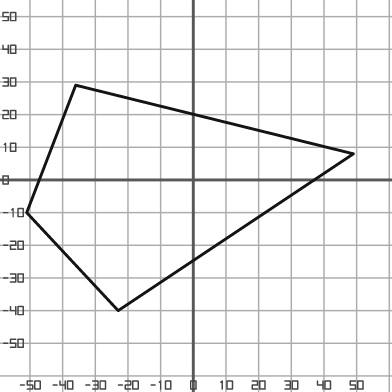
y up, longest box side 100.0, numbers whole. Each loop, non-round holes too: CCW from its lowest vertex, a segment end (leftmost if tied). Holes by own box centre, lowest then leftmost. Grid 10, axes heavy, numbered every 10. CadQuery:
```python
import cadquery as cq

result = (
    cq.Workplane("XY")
    .moveTo(-23.0, -40.0)
    .lineTo(49.0, 8.0)
    .lineTo(-36.0, 29.0)
    .lineTo(-51.0, -10.0)
    .close()
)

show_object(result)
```